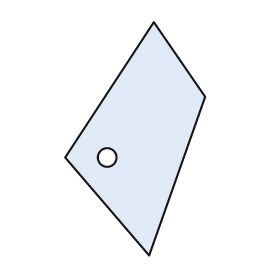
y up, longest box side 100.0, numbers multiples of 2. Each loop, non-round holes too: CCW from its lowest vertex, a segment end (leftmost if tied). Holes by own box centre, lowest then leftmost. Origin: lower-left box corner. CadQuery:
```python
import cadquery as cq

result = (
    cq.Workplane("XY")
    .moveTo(36.0, 0.0)
    .lineTo(60.0, 68.0)
    .lineTo(38.0, 100.0)
    .lineTo(0.0, 42.0)
    .close()
    .moveTo(18.0, 42.0)
    .circle(4.0)
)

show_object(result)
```